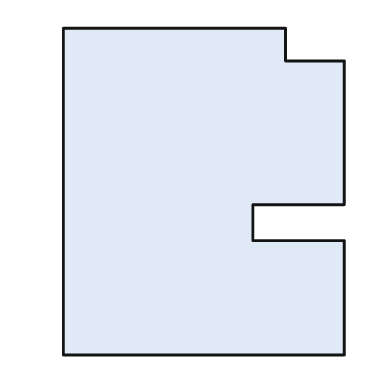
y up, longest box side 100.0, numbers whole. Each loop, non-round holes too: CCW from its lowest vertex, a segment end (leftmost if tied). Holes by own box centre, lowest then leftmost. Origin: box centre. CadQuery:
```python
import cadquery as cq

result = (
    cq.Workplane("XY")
    .moveTo(-43.0, -50.0)
    .lineTo(43.0, -50.0)
    .lineTo(43.0, -15.0)
    .lineTo(15.0, -15.0)
    .lineTo(15.0, -4.0)
    .lineTo(43.0, -4.0)
    .lineTo(43.0, 40.0)
    .lineTo(25.0, 40.0)
    .lineTo(25.0, 50.0)
    .lineTo(-43.0, 50.0)
    .close()
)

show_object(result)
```